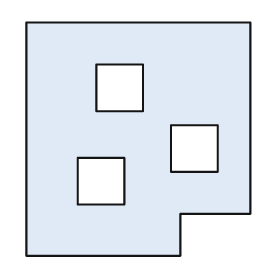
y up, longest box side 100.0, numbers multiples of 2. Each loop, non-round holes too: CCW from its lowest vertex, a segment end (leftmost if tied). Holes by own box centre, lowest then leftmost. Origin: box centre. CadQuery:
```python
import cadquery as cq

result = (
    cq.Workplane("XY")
    .moveTo(-48.0, -50.0)
    .lineTo(18.0, -50.0)
    .lineTo(18.0, -32.0)
    .lineTo(48.0, -32.0)
    .lineTo(48.0, 50.0)
    .lineTo(-48.0, 50.0)
    .close()
    .moveTo(-26.0, -28.0)
    .lineTo(-6.0, -28.0)
    .lineTo(-6.0, -8.0)
    .lineTo(-26.0, -8.0)
    .close()
    .moveTo(14.0, -14.0)
    .lineTo(34.0, -14.0)
    .lineTo(34.0, 6.0)
    .lineTo(14.0, 6.0)
    .close()
    .moveTo(-18.0, 12.0)
    .lineTo(2.0, 12.0)
    .lineTo(2.0, 32.0)
    .lineTo(-18.0, 32.0)
    .close()
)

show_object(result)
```